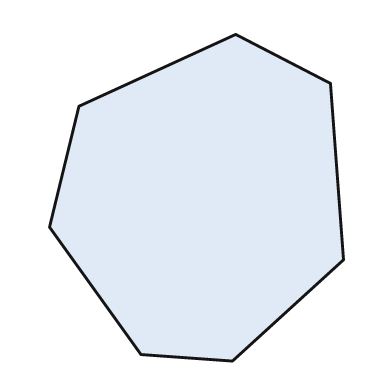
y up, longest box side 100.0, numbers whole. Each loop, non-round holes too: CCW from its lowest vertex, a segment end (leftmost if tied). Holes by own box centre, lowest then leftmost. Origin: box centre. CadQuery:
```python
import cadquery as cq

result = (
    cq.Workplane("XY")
    .moveTo(11.0, -50.0)
    .lineTo(45.0, -19.0)
    .lineTo(41.0, 35.0)
    .lineTo(12.0, 50.0)
    .lineTo(-36.0, 28.0)
    .lineTo(-45.0, -9.0)
    .lineTo(-17.0, -48.0)
    .close()
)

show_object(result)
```